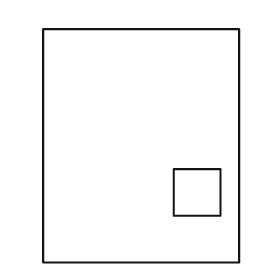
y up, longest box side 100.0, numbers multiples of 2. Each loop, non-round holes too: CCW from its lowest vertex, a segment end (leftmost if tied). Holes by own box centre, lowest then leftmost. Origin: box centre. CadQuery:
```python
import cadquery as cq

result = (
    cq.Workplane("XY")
    .moveTo(-42.0, -50.0)
    .lineTo(42.0, -50.0)
    .lineTo(42.0, 50.0)
    .lineTo(-42.0, 50.0)
    .close()
    .moveTo(14.0, -30.0)
    .lineTo(34.0, -30.0)
    .lineTo(34.0, -10.0)
    .lineTo(14.0, -10.0)
    .close()
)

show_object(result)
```